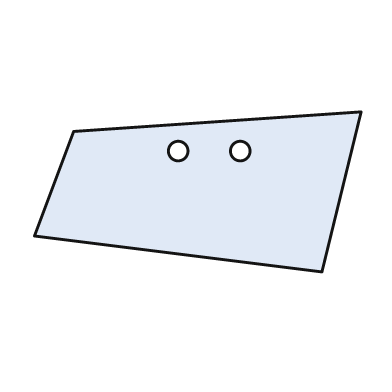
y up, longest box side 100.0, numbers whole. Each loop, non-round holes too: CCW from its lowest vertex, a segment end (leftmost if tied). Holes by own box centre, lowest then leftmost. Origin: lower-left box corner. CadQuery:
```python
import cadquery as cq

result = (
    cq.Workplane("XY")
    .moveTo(88.0, 0.0)
    .lineTo(100.0, 49.0)
    .lineTo(12.0, 43.0)
    .lineTo(0.0, 11.0)
    .close()
    .moveTo(44.0, 37.0)
    .circle(3.0)
    .moveTo(63.0, 37.0)
    .circle(3.0)
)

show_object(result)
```